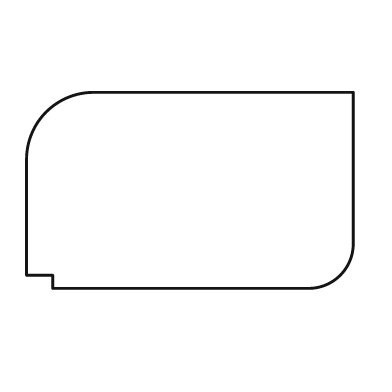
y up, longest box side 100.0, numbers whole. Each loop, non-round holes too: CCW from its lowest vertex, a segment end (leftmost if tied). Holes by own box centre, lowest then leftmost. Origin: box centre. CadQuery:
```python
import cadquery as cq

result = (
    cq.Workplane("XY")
    .moveTo(-42.0, -30.0)
    .lineTo(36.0, -30.0)
    .threePointArc((46.0, -26.0), (50.0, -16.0))
    .lineTo(50.0, 30.0)
    .lineTo(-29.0, 30.0)
    .threePointArc((-44.0, 24.0), (-50.0, 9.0))
    .lineTo(-50.0, -26.0)
    .lineTo(-42.0, -26.0)
    .close()
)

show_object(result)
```